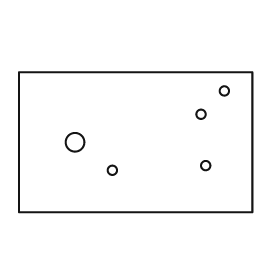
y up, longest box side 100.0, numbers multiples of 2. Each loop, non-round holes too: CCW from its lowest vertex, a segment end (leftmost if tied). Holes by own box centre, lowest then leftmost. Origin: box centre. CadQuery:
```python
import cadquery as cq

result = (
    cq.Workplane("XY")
    .moveTo(-50.0, -30.0)
    .lineTo(50.0, -30.0)
    .lineTo(50.0, 30.0)
    .lineTo(-50.0, 30.0)
    .close()
    .moveTo(-10.0, -12.0)
    .circle(2.0)
    .moveTo(30.0, -10.0)
    .circle(2.0)
    .moveTo(-26.0, 0.0)
    .circle(4.0)
    .moveTo(28.0, 12.0)
    .circle(2.0)
    .moveTo(38.0, 22.0)
    .circle(2.0)
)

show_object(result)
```